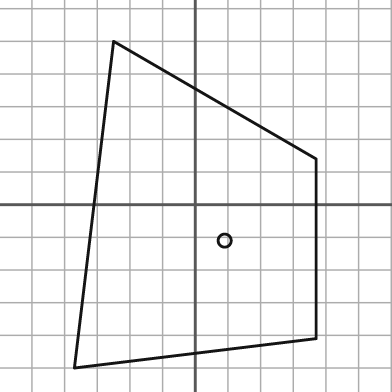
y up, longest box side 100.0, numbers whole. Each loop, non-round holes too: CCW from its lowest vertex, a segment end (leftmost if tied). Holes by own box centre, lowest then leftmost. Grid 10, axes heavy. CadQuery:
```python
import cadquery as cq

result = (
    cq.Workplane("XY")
    .moveTo(-37.0, -50.0)
    .lineTo(37.0, -41.0)
    .lineTo(37.0, 14.0)
    .lineTo(-25.0, 50.0)
    .close()
    .moveTo(9.0, -11.0)
    .circle(2.0)
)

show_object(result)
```